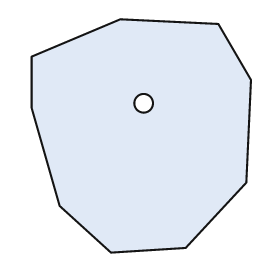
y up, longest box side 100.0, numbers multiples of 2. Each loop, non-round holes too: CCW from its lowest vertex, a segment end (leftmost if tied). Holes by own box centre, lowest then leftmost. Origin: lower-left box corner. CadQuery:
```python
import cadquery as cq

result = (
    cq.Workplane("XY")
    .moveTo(34.0, 0.0)
    .lineTo(66.0, 2.0)
    .lineTo(92.0, 30.0)
    .lineTo(94.0, 74.0)
    .lineTo(80.0, 98.0)
    .lineTo(38.0, 100.0)
    .lineTo(0.0, 84.0)
    .lineTo(0.0, 62.0)
    .lineTo(12.0, 20.0)
    .close()
    .moveTo(48.0, 64.0)
    .circle(4.0)
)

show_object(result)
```